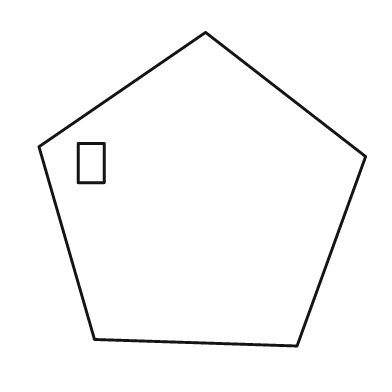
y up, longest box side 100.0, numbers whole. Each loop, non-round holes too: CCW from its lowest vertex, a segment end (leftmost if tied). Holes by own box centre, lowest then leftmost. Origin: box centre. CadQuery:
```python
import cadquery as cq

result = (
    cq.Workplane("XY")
    .moveTo(29.0, -48.0)
    .lineTo(50.0, 10.0)
    .lineTo(1.0, 48.0)
    .lineTo(-50.0, 13.0)
    .lineTo(-33.0, -46.0)
    .close()
    .moveTo(-38.0, 2.0)
    .lineTo(-30.0, 2.0)
    .lineTo(-30.0, 14.0)
    .lineTo(-38.0, 14.0)
    .close()
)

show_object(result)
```